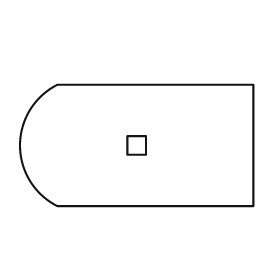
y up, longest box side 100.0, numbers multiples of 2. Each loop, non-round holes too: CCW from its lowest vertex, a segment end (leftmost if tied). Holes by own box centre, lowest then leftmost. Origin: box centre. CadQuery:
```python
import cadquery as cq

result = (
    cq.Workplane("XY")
    .moveTo(-34.0, -26.0)
    .lineTo(50.0, -26.0)
    .lineTo(50.0, 26.0)
    .lineTo(-34.0, 26.0)
    .threePointArc((-50.0, 0.0), (-34.0, -26.0))
    .close()
    .moveTo(-4.0, -4.0)
    .lineTo(4.0, -4.0)
    .lineTo(4.0, 4.0)
    .lineTo(-4.0, 4.0)
    .close()
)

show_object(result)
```